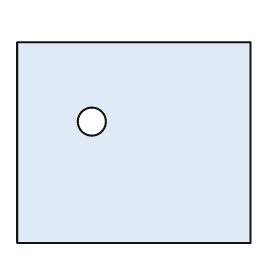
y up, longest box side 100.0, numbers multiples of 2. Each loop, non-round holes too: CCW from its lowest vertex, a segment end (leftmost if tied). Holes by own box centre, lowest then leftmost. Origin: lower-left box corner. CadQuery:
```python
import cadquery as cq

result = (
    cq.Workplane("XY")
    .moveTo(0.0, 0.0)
    .lineTo(100.0, 0.0)
    .lineTo(100.0, 86.0)
    .lineTo(0.0, 86.0)
    .close()
    .moveTo(32.0, 52.0)
    .circle(6.0)
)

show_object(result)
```